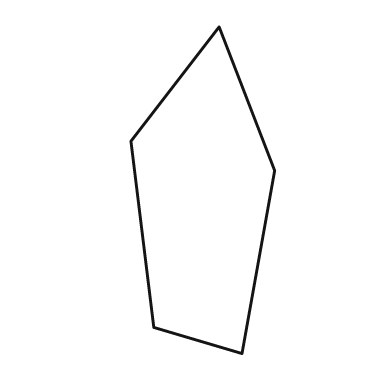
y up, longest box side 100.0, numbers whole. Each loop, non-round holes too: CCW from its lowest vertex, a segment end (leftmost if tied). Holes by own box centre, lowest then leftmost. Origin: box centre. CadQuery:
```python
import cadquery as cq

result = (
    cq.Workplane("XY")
    .moveTo(12.0, -50.0)
    .lineTo(22.0, 6.0)
    .lineTo(5.0, 50.0)
    .lineTo(-22.0, 15.0)
    .lineTo(-15.0, -42.0)
    .close()
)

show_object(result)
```